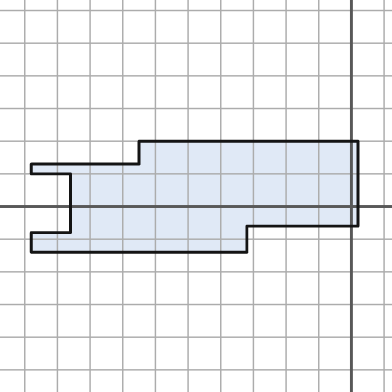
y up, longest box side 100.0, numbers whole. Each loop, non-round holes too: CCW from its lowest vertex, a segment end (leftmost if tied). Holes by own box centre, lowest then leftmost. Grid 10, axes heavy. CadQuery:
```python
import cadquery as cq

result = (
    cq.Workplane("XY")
    .moveTo(-98.0, -14.0)
    .lineTo(-32.0, -14.0)
    .lineTo(-32.0, -6.0)
    .lineTo(2.0, -6.0)
    .lineTo(2.0, 20.0)
    .lineTo(-65.0, 20.0)
    .lineTo(-65.0, 13.0)
    .lineTo(-98.0, 13.0)
    .lineTo(-98.0, 10.0)
    .lineTo(-86.0, 10.0)
    .lineTo(-86.0, -8.0)
    .lineTo(-98.0, -8.0)
    .close()
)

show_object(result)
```